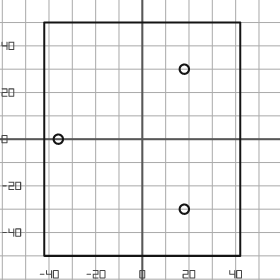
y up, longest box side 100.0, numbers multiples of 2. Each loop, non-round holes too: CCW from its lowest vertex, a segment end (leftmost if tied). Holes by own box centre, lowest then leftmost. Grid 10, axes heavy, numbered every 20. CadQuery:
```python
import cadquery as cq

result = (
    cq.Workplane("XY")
    .moveTo(-42.0, -50.0)
    .lineTo(42.0, -50.0)
    .lineTo(42.0, 50.0)
    .lineTo(-42.0, 50.0)
    .close()
    .moveTo(18.0, -30.0)
    .circle(2.0)
    .moveTo(-36.0, 0.0)
    .circle(2.0)
    .moveTo(18.0, 30.0)
    .circle(2.0)
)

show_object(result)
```